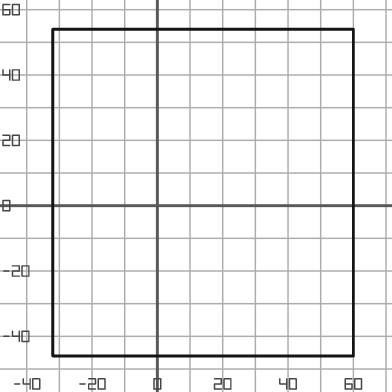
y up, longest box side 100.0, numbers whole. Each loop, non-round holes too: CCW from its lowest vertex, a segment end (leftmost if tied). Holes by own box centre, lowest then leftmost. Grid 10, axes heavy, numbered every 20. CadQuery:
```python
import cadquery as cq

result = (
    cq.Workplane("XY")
    .moveTo(-32.0, -46.0)
    .lineTo(60.0, -46.0)
    .lineTo(60.0, 54.0)
    .lineTo(-32.0, 54.0)
    .close()
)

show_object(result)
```